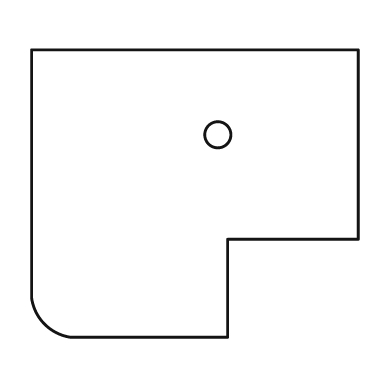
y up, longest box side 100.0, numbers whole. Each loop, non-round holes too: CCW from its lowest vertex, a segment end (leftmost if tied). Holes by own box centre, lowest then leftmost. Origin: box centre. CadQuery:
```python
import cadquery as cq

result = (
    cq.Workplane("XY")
    .moveTo(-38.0, -44.0)
    .lineTo(10.0, -44.0)
    .lineTo(10.0, -14.0)
    .lineTo(50.0, -14.0)
    .lineTo(50.0, 44.0)
    .lineTo(-50.0, 44.0)
    .lineTo(-50.0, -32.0)
    .threePointArc((-46.0, -40.0), (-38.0, -44.0))
    .close()
    .moveTo(7.0, 18.0)
    .circle(4.0)
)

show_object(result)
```